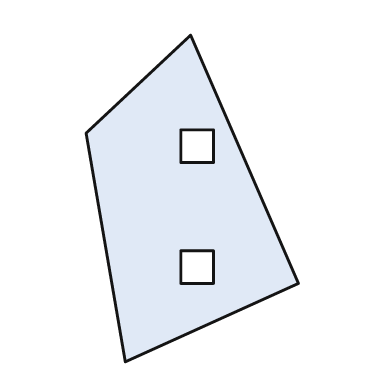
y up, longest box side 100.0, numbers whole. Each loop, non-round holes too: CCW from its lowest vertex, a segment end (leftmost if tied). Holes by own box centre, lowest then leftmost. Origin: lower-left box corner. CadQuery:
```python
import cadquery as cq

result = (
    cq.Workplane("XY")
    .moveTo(12.0, 0.0)
    .lineTo(65.0, 24.0)
    .lineTo(32.0, 100.0)
    .lineTo(0.0, 70.0)
    .close()
    .moveTo(29.0, 24.0)
    .lineTo(39.0, 24.0)
    .lineTo(39.0, 34.0)
    .lineTo(29.0, 34.0)
    .close()
    .moveTo(29.0, 61.0)
    .lineTo(39.0, 61.0)
    .lineTo(39.0, 71.0)
    .lineTo(29.0, 71.0)
    .close()
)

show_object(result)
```